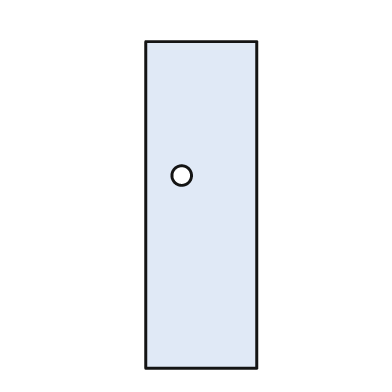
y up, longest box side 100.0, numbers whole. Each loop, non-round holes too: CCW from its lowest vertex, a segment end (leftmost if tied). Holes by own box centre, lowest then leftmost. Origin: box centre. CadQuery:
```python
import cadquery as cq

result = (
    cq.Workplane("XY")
    .moveTo(-17.0, -50.0)
    .lineTo(17.0, -50.0)
    .lineTo(17.0, 50.0)
    .lineTo(-17.0, 50.0)
    .close()
    .moveTo(-6.0, 9.0)
    .circle(3.0)
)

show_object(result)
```